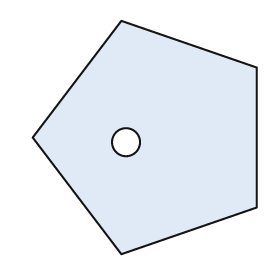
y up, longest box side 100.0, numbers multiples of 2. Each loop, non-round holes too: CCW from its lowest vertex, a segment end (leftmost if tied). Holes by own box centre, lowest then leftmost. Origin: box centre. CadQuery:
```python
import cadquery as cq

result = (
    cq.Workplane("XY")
    .moveTo(-10.0, -50.0)
    .lineTo(48.0, -30.0)
    .lineTo(48.0, 30.0)
    .lineTo(-10.0, 50.0)
    .lineTo(-48.0, 0.0)
    .close()
    .moveTo(-8.0, -2.0)
    .circle(6.0)
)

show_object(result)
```